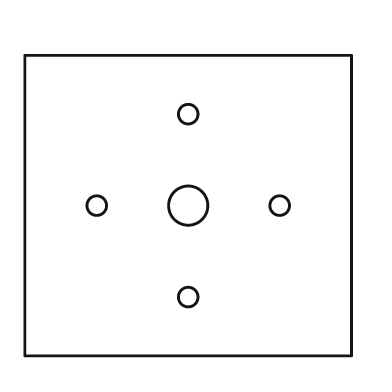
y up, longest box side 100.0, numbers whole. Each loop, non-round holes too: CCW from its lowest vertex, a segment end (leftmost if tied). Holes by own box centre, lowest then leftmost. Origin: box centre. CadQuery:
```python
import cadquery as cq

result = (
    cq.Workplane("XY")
    .moveTo(-50.0, -46.0)
    .lineTo(50.0, -46.0)
    .lineTo(50.0, 46.0)
    .lineTo(-50.0, 46.0)
    .close()
    .moveTo(0.0, -28.0)
    .circle(3.0)
    .moveTo(-28.0, 0.0)
    .circle(3.0)
    .moveTo(0.0, 0.0)
    .circle(6.0)
    .moveTo(28.0, 0.0)
    .circle(3.0)
    .moveTo(0.0, 28.0)
    .circle(3.0)
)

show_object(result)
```